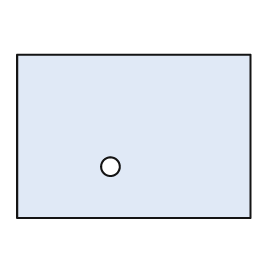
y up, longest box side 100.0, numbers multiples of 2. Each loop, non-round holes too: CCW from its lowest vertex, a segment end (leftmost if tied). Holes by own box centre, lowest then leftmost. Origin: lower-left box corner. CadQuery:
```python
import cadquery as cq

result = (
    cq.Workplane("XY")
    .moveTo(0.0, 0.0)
    .lineTo(100.0, 0.0)
    .lineTo(100.0, 70.0)
    .lineTo(0.0, 70.0)
    .close()
    .moveTo(40.0, 22.0)
    .circle(4.0)
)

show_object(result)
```